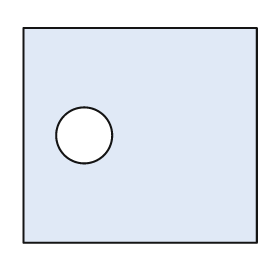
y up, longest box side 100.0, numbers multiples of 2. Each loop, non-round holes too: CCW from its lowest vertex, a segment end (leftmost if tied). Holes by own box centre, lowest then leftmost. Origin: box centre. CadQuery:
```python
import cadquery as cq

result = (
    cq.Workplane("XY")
    .moveTo(-50.0, -46.0)
    .lineTo(50.0, -46.0)
    .lineTo(50.0, 46.0)
    .lineTo(-50.0, 46.0)
    .close()
    .moveTo(-24.0, 0.0)
    .circle(12.0)
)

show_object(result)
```